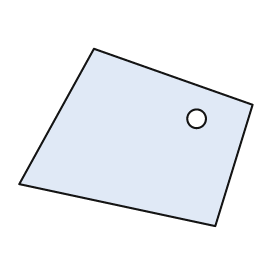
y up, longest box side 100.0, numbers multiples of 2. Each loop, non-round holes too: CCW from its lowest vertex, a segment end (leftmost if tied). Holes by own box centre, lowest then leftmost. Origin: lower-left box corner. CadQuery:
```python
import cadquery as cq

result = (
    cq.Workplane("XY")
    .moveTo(84.0, 0.0)
    .lineTo(100.0, 52.0)
    .lineTo(32.0, 76.0)
    .lineTo(0.0, 18.0)
    .close()
    .moveTo(76.0, 46.0)
    .circle(4.0)
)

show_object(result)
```